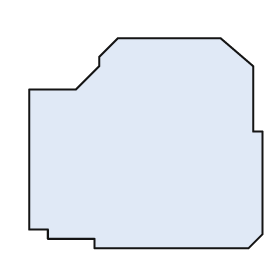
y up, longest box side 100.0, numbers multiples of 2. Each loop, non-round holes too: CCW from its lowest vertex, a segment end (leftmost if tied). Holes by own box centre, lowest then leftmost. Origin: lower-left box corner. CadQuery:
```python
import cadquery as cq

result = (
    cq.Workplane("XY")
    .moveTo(28.0, 0.0)
    .lineTo(94.0, 0.0)
    .lineTo(100.0, 6.0)
    .lineTo(100.0, 50.0)
    .lineTo(96.0, 50.0)
    .lineTo(96.0, 78.0)
    .lineTo(82.0, 90.0)
    .lineTo(38.0, 90.0)
    .lineTo(30.0, 82.0)
    .lineTo(30.0, 78.0)
    .lineTo(20.0, 68.0)
    .lineTo(0.0, 68.0)
    .lineTo(0.0, 8.0)
    .lineTo(8.0, 8.0)
    .lineTo(8.0, 4.0)
    .lineTo(28.0, 4.0)
    .close()
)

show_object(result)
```